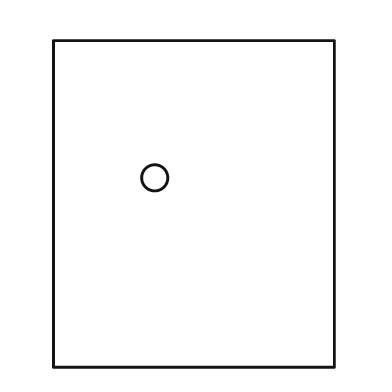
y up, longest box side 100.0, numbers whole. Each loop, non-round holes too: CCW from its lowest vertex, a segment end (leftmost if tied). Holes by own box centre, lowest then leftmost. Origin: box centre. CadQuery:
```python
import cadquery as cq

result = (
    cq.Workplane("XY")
    .moveTo(-43.0, -50.0)
    .lineTo(43.0, -50.0)
    .lineTo(43.0, 50.0)
    .lineTo(-43.0, 50.0)
    .close()
    .moveTo(-12.0, 8.0)
    .circle(4.0)
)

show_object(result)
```